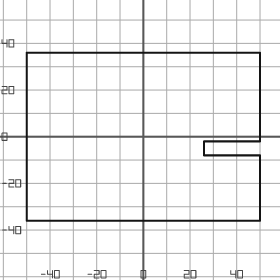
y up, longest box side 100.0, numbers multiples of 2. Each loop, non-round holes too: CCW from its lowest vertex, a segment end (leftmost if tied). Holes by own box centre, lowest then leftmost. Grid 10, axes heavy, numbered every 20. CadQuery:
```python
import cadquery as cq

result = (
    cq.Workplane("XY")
    .moveTo(-50.0, -36.0)
    .lineTo(50.0, -36.0)
    .lineTo(50.0, -8.0)
    .lineTo(26.0, -8.0)
    .lineTo(26.0, -2.0)
    .lineTo(50.0, -2.0)
    .lineTo(50.0, 36.0)
    .lineTo(-50.0, 36.0)
    .close()
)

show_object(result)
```